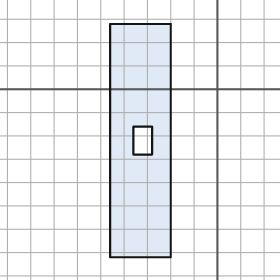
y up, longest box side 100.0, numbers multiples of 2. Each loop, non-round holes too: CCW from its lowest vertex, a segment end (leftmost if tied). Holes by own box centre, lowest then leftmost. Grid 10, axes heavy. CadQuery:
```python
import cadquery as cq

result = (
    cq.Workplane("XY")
    .moveTo(-46.0, -72.0)
    .lineTo(-20.0, -72.0)
    .lineTo(-20.0, 28.0)
    .lineTo(-46.0, 28.0)
    .close()
    .moveTo(-36.0, -28.0)
    .lineTo(-28.0, -28.0)
    .lineTo(-28.0, -16.0)
    .lineTo(-36.0, -16.0)
    .close()
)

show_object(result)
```